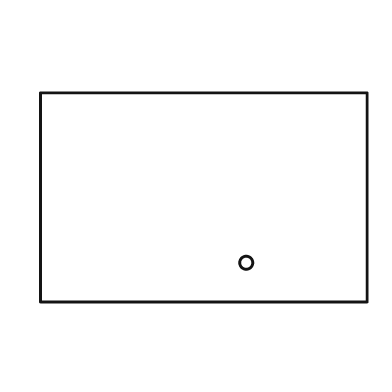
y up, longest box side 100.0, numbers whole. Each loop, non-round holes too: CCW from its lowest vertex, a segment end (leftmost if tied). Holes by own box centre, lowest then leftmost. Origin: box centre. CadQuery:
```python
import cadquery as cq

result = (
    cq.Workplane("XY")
    .moveTo(-50.0, -32.0)
    .lineTo(50.0, -32.0)
    .lineTo(50.0, 32.0)
    .lineTo(-50.0, 32.0)
    .close()
    .moveTo(13.0, -20.0)
    .circle(2.0)
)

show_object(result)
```